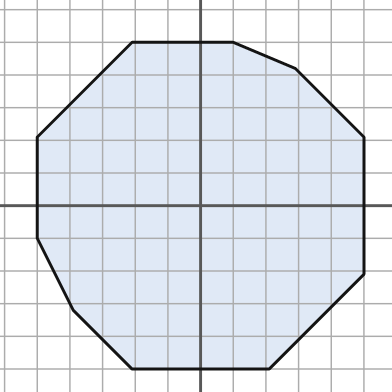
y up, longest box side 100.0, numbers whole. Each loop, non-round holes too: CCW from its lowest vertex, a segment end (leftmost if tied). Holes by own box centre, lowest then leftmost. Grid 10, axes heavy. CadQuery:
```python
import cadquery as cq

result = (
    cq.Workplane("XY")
    .moveTo(-21.0, -50.0)
    .lineTo(21.0, -50.0)
    .lineTo(50.0, -21.0)
    .lineTo(50.0, 21.0)
    .lineTo(29.0, 42.0)
    .lineTo(10.0, 50.0)
    .lineTo(-21.0, 50.0)
    .lineTo(-50.0, 21.0)
    .lineTo(-50.0, -10.0)
    .lineTo(-39.0, -32.0)
    .close()
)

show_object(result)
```